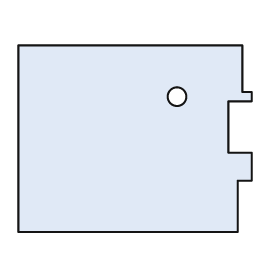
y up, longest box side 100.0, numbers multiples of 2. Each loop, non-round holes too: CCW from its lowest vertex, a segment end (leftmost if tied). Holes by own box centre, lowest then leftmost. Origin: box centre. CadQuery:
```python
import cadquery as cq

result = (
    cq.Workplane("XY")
    .moveTo(-50.0, -40.0)
    .lineTo(44.0, -40.0)
    .lineTo(44.0, -18.0)
    .lineTo(50.0, -18.0)
    .lineTo(50.0, -6.0)
    .lineTo(40.0, -6.0)
    .lineTo(40.0, 16.0)
    .lineTo(50.0, 16.0)
    .lineTo(50.0, 20.0)
    .lineTo(46.0, 20.0)
    .lineTo(46.0, 40.0)
    .lineTo(-50.0, 40.0)
    .close()
    .moveTo(18.0, 18.0)
    .circle(4.0)
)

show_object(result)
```